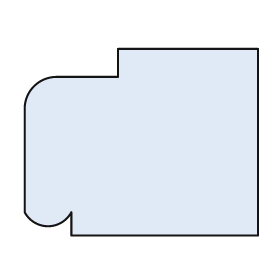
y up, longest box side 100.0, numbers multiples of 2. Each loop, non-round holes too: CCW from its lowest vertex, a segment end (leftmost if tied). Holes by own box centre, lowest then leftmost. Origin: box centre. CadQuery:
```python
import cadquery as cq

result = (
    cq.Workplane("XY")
    .moveTo(-30.0, -40.0)
    .lineTo(50.0, -40.0)
    .lineTo(50.0, 40.0)
    .lineTo(-10.0, 40.0)
    .lineTo(-10.0, 28.0)
    .lineTo(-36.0, 28.0)
    .threePointArc((-46.0, 24.0), (-50.0, 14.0))
    .lineTo(-50.0, -30.0)
    .threePointArc((-40.0, -36.0), (-30.0, -30.0))
    .close()
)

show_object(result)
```